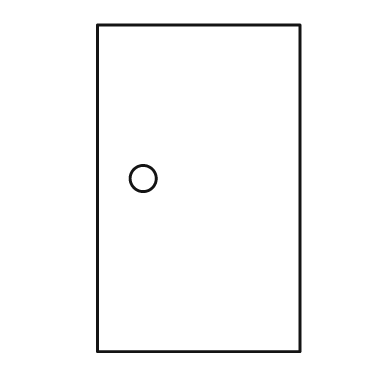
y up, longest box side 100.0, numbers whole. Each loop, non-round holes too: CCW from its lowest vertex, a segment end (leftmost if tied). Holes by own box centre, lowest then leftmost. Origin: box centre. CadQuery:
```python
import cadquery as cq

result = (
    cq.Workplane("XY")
    .moveTo(-31.0, -50.0)
    .lineTo(31.0, -50.0)
    .lineTo(31.0, 50.0)
    .lineTo(-31.0, 50.0)
    .close()
    .moveTo(-17.0, 3.0)
    .circle(4.0)
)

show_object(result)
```